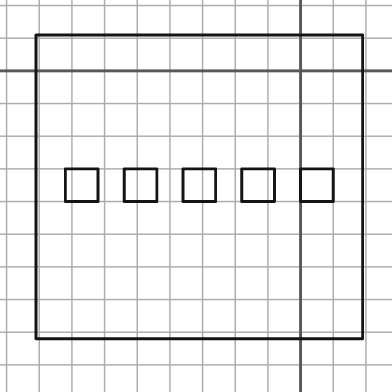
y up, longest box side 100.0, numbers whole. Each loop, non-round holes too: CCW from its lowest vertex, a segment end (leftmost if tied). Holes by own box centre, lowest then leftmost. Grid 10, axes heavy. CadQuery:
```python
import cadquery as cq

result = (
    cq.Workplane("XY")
    .moveTo(-81.0, -82.0)
    .lineTo(19.0, -82.0)
    .lineTo(19.0, 11.0)
    .lineTo(-81.0, 11.0)
    .close()
    .moveTo(-72.0, -40.0)
    .lineTo(-62.0, -40.0)
    .lineTo(-62.0, -30.0)
    .lineTo(-72.0, -30.0)
    .close()
    .moveTo(-54.0, -40.0)
    .lineTo(-44.0, -40.0)
    .lineTo(-44.0, -30.0)
    .lineTo(-54.0, -30.0)
    .close()
    .moveTo(-36.0, -40.0)
    .lineTo(-26.0, -40.0)
    .lineTo(-26.0, -30.0)
    .lineTo(-36.0, -30.0)
    .close()
    .moveTo(-18.0, -40.0)
    .lineTo(-8.0, -40.0)
    .lineTo(-8.0, -30.0)
    .lineTo(-18.0, -30.0)
    .close()
    .moveTo(0.0, -40.0)
    .lineTo(10.0, -40.0)
    .lineTo(10.0, -30.0)
    .lineTo(0.0, -30.0)
    .close()
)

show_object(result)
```